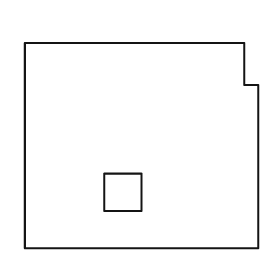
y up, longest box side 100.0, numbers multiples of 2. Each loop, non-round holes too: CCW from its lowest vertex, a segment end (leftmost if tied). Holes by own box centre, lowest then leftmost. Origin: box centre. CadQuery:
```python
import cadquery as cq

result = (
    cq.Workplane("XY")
    .moveTo(-50.0, -44.0)
    .lineTo(50.0, -44.0)
    .lineTo(50.0, 26.0)
    .lineTo(44.0, 26.0)
    .lineTo(44.0, 44.0)
    .lineTo(-50.0, 44.0)
    .close()
    .moveTo(-16.0, -28.0)
    .lineTo(0.0, -28.0)
    .lineTo(0.0, -12.0)
    .lineTo(-16.0, -12.0)
    .close()
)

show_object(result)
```